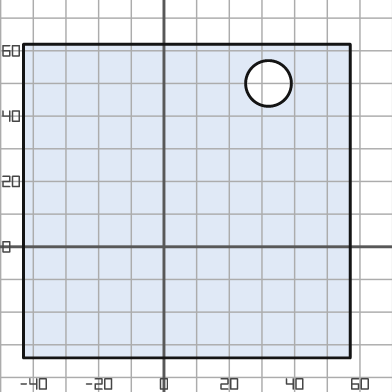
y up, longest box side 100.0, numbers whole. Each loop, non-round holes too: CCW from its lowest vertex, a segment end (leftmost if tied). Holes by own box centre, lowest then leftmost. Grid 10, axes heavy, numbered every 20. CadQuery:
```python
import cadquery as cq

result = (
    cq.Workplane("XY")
    .moveTo(-43.0, -34.0)
    .lineTo(57.0, -34.0)
    .lineTo(57.0, 62.0)
    .lineTo(-43.0, 62.0)
    .close()
    .moveTo(32.0, 50.0)
    .circle(7.0)
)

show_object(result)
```